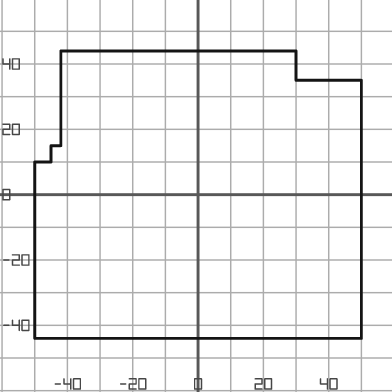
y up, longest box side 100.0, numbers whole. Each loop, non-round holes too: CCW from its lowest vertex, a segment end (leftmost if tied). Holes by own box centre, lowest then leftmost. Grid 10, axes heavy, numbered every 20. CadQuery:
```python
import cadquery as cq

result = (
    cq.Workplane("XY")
    .moveTo(-50.0, -44.0)
    .lineTo(50.0, -44.0)
    .lineTo(50.0, 35.0)
    .lineTo(30.0, 35.0)
    .lineTo(30.0, 44.0)
    .lineTo(-42.0, 44.0)
    .lineTo(-42.0, 15.0)
    .lineTo(-45.0, 15.0)
    .lineTo(-45.0, 10.0)
    .lineTo(-50.0, 10.0)
    .close()
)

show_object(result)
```